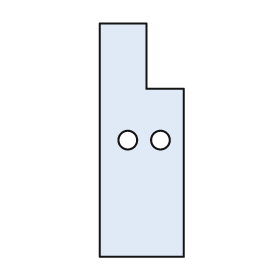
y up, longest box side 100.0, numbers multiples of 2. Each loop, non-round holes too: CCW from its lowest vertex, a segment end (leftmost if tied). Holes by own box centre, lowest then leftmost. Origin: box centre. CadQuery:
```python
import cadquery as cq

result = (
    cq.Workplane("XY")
    .moveTo(-18.0, -50.0)
    .lineTo(18.0, -50.0)
    .lineTo(18.0, 22.0)
    .lineTo(2.0, 22.0)
    .lineTo(2.0, 50.0)
    .lineTo(-18.0, 50.0)
    .close()
    .moveTo(-6.0, 0.0)
    .circle(4.0)
    .moveTo(8.0, 0.0)
    .circle(4.0)
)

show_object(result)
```